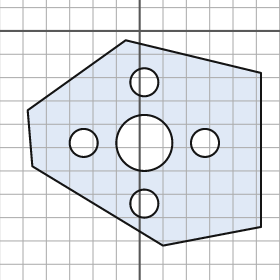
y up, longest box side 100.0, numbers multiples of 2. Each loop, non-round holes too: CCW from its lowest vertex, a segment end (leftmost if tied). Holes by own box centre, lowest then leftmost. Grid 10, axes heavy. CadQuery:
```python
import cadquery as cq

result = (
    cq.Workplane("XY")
    .moveTo(10.0, -92.0)
    .lineTo(52.0, -84.0)
    .lineTo(52.0, -18.0)
    .lineTo(-6.0, -4.0)
    .lineTo(-48.0, -34.0)
    .lineTo(-46.0, -58.0)
    .close()
    .moveTo(2.0, -74.0)
    .circle(6.0)
    .moveTo(-24.0, -48.0)
    .circle(6.0)
    .moveTo(2.0, -48.0)
    .circle(12.0)
    .moveTo(28.0, -48.0)
    .circle(6.0)
    .moveTo(2.0, -22.0)
    .circle(6.0)
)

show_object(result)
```